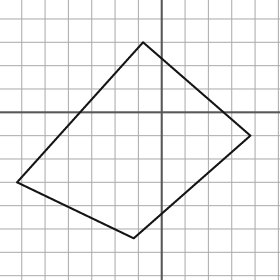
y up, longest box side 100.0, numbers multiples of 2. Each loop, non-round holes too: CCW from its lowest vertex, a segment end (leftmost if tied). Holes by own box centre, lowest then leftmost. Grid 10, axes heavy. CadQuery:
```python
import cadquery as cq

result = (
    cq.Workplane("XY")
    .moveTo(-12.0, -54.0)
    .lineTo(38.0, -10.0)
    .lineTo(-8.0, 30.0)
    .lineTo(-62.0, -30.0)
    .close()
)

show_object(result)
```